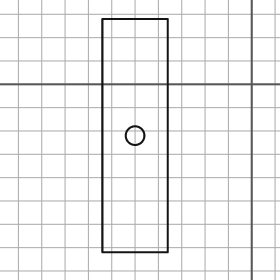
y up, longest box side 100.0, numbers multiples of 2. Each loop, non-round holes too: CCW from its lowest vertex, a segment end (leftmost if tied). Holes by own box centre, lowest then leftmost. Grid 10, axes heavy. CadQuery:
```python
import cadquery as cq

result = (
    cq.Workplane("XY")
    .moveTo(-64.0, -72.0)
    .lineTo(-36.0, -72.0)
    .lineTo(-36.0, 28.0)
    .lineTo(-64.0, 28.0)
    .close()
    .moveTo(-50.0, -22.0)
    .circle(4.0)
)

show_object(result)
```